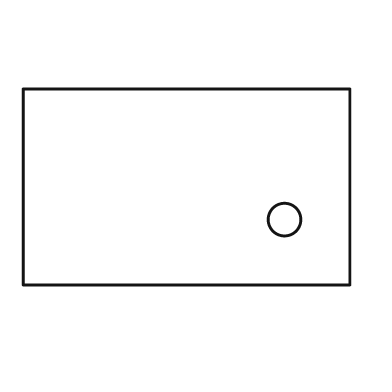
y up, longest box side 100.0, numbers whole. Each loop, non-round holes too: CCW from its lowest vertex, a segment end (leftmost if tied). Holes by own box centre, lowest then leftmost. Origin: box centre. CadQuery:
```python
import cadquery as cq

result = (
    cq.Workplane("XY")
    .moveTo(-50.0, -30.0)
    .lineTo(50.0, -30.0)
    .lineTo(50.0, 30.0)
    .lineTo(-50.0, 30.0)
    .close()
    .moveTo(30.0, -10.0)
    .circle(5.0)
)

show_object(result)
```